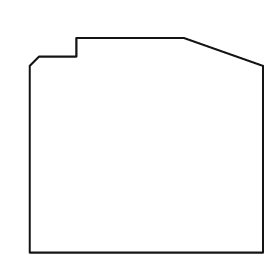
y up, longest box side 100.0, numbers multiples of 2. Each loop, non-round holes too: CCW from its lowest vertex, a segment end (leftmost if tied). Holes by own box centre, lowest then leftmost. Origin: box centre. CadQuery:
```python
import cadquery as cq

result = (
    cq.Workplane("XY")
    .moveTo(-50.0, -46.0)
    .lineTo(50.0, -46.0)
    .lineTo(50.0, 34.0)
    .lineTo(16.0, 46.0)
    .lineTo(-30.0, 46.0)
    .lineTo(-30.0, 38.0)
    .lineTo(-46.0, 38.0)
    .lineTo(-50.0, 34.0)
    .close()
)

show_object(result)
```